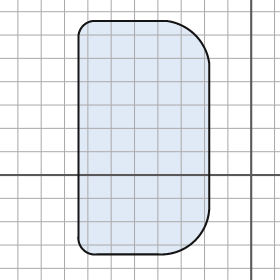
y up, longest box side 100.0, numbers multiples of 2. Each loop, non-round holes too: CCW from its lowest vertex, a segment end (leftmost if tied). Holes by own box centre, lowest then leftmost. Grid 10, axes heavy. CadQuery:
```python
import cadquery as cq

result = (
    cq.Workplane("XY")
    .moveTo(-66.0, -34.0)
    .lineTo(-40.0, -34.0)
    .threePointArc((-24.0, -28.0), (-18.0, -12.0))
    .lineTo(-18.0, 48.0)
    .threePointArc((-24.0, 60.0), (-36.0, 66.0))
    .lineTo(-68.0, 66.0)
    .threePointArc((-72.0, 64.0), (-74.0, 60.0))
    .lineTo(-74.0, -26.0)
    .threePointArc((-72.0, -32.0), (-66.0, -34.0))
    .close()
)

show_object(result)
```